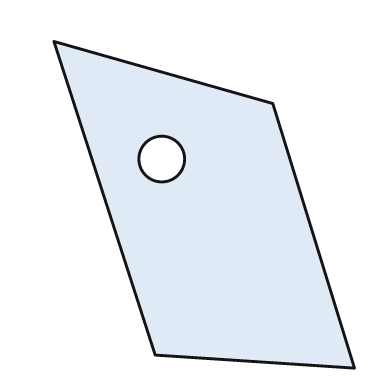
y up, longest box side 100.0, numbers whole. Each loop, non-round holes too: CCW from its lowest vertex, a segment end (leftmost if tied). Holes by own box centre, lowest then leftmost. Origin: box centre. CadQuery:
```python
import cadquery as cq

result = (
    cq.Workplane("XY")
    .moveTo(46.0, -50.0)
    .lineTo(21.0, 31.0)
    .lineTo(-46.0, 50.0)
    .lineTo(-15.0, -46.0)
    .close()
    .moveTo(-13.0, 14.0)
    .circle(7.0)
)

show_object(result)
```